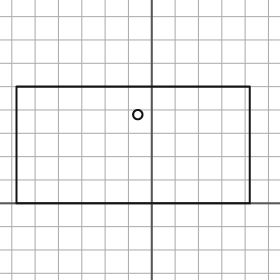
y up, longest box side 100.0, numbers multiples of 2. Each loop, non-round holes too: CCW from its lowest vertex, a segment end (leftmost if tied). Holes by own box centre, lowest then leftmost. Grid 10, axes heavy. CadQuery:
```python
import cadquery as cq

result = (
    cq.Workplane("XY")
    .moveTo(-58.0, 0.0)
    .lineTo(42.0, 0.0)
    .lineTo(42.0, 50.0)
    .lineTo(-58.0, 50.0)
    .close()
    .moveTo(-6.0, 38.0)
    .circle(2.0)
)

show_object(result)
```